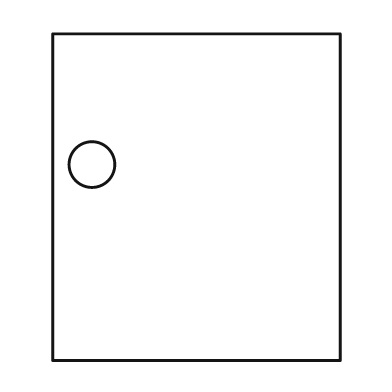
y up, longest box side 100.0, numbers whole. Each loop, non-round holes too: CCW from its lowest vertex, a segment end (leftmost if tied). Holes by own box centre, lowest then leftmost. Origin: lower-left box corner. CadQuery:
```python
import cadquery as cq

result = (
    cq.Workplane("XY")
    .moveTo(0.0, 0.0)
    .lineTo(88.0, 0.0)
    .lineTo(88.0, 100.0)
    .lineTo(0.0, 100.0)
    .close()
    .moveTo(12.0, 60.0)
    .circle(7.0)
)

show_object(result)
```